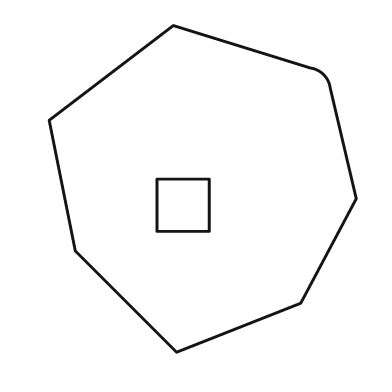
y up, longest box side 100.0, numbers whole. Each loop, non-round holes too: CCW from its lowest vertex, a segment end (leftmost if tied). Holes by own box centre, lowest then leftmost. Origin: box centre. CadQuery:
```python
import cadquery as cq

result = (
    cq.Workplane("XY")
    .moveTo(-8.0, -50.0)
    .lineTo(30.0, -35.0)
    .lineTo(47.0, -3.0)
    .lineTo(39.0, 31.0)
    .threePointArc((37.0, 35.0), (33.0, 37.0))
    .lineTo(-9.0, 50.0)
    .lineTo(-47.0, 21.0)
    .lineTo(-39.0, -19.0)
    .close()
    .moveTo(-14.0, -13.0)
    .lineTo(2.0, -13.0)
    .lineTo(2.0, 3.0)
    .lineTo(-14.0, 3.0)
    .close()
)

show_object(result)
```